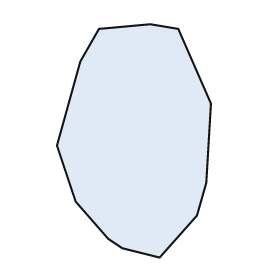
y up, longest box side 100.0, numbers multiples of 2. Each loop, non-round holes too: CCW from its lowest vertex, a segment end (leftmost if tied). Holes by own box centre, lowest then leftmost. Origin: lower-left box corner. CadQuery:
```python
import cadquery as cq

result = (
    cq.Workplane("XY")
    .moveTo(44.0, 0.0)
    .lineTo(60.0, 18.0)
    .lineTo(64.0, 32.0)
    .lineTo(66.0, 66.0)
    .lineTo(52.0, 98.0)
    .lineTo(40.0, 100.0)
    .lineTo(18.0, 98.0)
    .lineTo(10.0, 84.0)
    .lineTo(0.0, 48.0)
    .lineTo(8.0, 24.0)
    .lineTo(22.0, 8.0)
    .lineTo(28.0, 4.0)
    .close()
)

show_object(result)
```